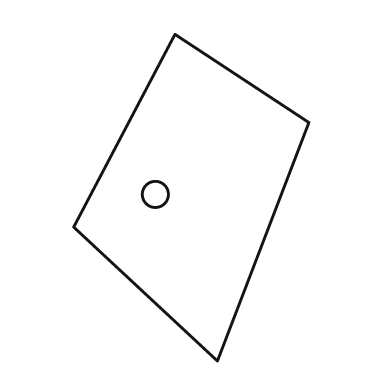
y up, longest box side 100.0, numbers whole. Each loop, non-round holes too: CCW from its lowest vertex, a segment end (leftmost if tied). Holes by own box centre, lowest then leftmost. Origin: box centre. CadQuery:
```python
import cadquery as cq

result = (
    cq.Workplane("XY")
    .moveTo(8.0, -50.0)
    .lineTo(36.0, 23.0)
    .lineTo(-5.0, 50.0)
    .lineTo(-36.0, -9.0)
    .close()
    .moveTo(-11.0, 1.0)
    .circle(4.0)
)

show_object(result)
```